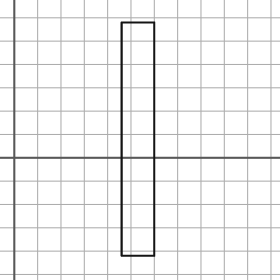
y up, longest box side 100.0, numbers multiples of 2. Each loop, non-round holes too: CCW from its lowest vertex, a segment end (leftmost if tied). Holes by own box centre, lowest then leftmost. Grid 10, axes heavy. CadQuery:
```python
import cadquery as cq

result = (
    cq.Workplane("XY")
    .moveTo(46.0, -42.0)
    .lineTo(60.0, -42.0)
    .lineTo(60.0, 58.0)
    .lineTo(46.0, 58.0)
    .close()
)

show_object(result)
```